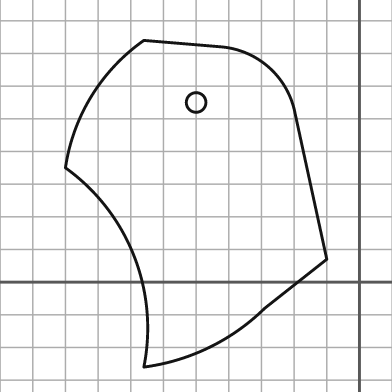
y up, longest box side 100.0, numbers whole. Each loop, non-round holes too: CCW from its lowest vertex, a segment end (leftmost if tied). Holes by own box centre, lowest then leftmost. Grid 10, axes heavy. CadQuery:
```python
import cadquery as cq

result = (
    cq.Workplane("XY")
    .moveTo(-66.0, -26.0)
    .threePointArc((-46.0, -20.0), (-29.0, -8.0))
    .lineTo(-10.0, 7.0)
    .lineTo(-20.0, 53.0)
    .threePointArc((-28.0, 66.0), (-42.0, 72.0))
    .lineTo(-66.0, 74.0)
    .threePointArc((-82.0, 57.0), (-90.0, 35.0))
    .threePointArc((-69.0, 8.0), (-66.0, -26.0))
    .close()
    .moveTo(-50.0, 55.0)
    .circle(3.0)
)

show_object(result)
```